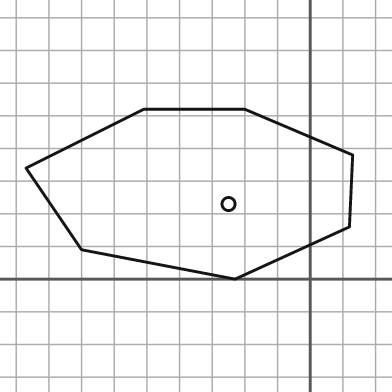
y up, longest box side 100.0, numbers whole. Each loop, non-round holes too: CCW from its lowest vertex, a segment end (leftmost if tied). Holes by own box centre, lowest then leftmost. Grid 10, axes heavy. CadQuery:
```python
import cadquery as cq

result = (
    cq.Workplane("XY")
    .moveTo(-23.0, 0.0)
    .lineTo(12.0, 16.0)
    .lineTo(13.0, 38.0)
    .lineTo(-20.0, 52.0)
    .lineTo(-51.0, 52.0)
    .lineTo(-87.0, 34.0)
    .lineTo(-70.0, 9.0)
    .close()
    .moveTo(-25.0, 23.0)
    .circle(2.0)
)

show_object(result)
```